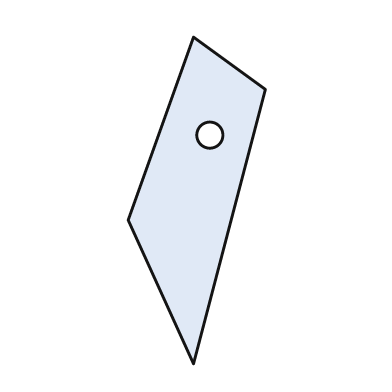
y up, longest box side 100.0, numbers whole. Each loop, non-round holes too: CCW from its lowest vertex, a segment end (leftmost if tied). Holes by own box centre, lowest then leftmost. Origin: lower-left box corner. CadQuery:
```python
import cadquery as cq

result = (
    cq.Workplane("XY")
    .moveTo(20.0, 0.0)
    .lineTo(42.0, 84.0)
    .lineTo(20.0, 100.0)
    .lineTo(0.0, 44.0)
    .close()
    .moveTo(25.0, 70.0)
    .circle(4.0)
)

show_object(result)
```